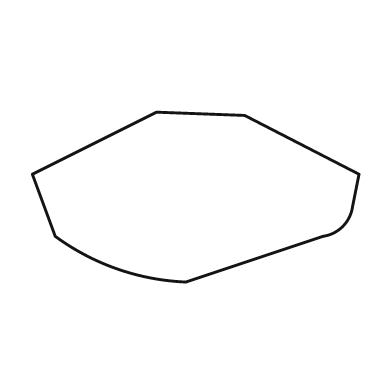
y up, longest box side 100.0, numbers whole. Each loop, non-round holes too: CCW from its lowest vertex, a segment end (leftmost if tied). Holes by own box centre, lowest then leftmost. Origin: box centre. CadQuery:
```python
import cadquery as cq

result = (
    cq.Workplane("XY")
    .moveTo(-3.0, -26.0)
    .lineTo(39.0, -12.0)
    .threePointArc((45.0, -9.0), (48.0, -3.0))
    .lineTo(50.0, 7.0)
    .lineTo(15.0, 25.0)
    .lineTo(-12.0, 26.0)
    .lineTo(-50.0, 7.0)
    .lineTo(-43.0, -12.0)
    .threePointArc((-24.0, -22.0), (-3.0, -26.0))
    .close()
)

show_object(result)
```